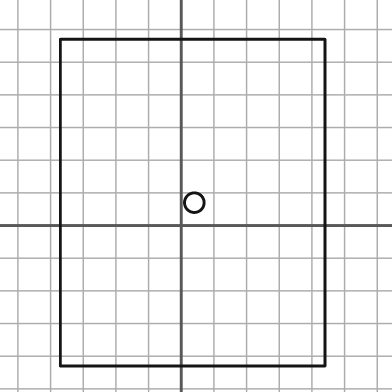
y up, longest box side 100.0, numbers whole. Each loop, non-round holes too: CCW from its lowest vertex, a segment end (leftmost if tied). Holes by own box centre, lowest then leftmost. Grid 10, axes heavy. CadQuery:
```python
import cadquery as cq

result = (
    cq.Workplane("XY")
    .moveTo(-37.0, -43.0)
    .lineTo(44.0, -43.0)
    .lineTo(44.0, 57.0)
    .lineTo(-37.0, 57.0)
    .close()
    .moveTo(4.0, 7.0)
    .circle(3.0)
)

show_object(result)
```